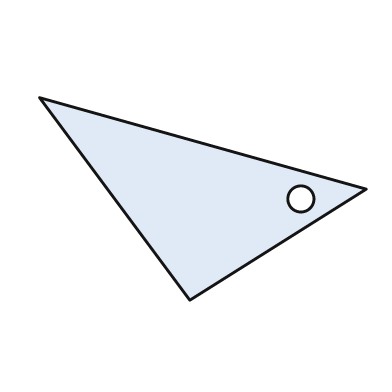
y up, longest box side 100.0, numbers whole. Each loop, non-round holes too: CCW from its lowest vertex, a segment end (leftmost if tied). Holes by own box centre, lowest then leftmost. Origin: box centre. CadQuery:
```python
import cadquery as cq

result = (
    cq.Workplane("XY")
    .moveTo(-4.0, -31.0)
    .lineTo(50.0, 3.0)
    .lineTo(-50.0, 31.0)
    .close()
    .moveTo(30.0, 0.0)
    .circle(4.0)
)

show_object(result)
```